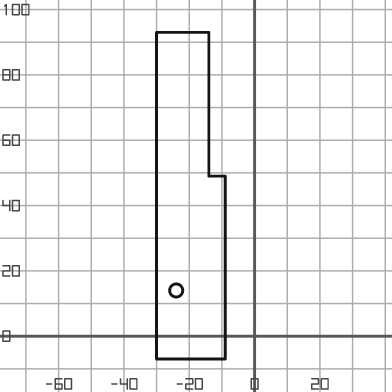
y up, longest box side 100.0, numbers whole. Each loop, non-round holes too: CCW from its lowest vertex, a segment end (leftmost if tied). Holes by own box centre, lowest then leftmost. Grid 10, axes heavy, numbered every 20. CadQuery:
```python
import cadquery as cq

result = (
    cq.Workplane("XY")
    .moveTo(-30.0, -7.0)
    .lineTo(-9.0, -7.0)
    .lineTo(-9.0, 49.0)
    .lineTo(-14.0, 49.0)
    .lineTo(-14.0, 93.0)
    .lineTo(-30.0, 93.0)
    .close()
    .moveTo(-24.0, 14.0)
    .circle(2.0)
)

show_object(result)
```